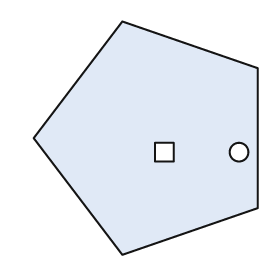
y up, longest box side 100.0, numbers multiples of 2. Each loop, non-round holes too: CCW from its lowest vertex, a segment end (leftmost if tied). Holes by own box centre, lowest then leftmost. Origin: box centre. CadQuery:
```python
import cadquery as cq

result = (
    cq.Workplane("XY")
    .moveTo(-10.0, -50.0)
    .lineTo(48.0, -30.0)
    .lineTo(48.0, 30.0)
    .lineTo(-10.0, 50.0)
    .lineTo(-48.0, 0.0)
    .close()
    .moveTo(4.0, -10.0)
    .lineTo(12.0, -10.0)
    .lineTo(12.0, -2.0)
    .lineTo(4.0, -2.0)
    .close()
    .moveTo(40.0, -6.0)
    .circle(4.0)
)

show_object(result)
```